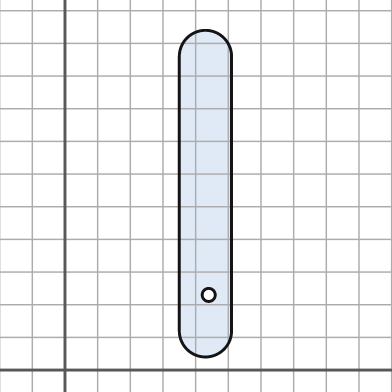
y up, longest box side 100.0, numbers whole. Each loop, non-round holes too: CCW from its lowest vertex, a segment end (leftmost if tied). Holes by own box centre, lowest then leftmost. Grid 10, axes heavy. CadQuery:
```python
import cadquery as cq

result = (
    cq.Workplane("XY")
    .moveTo(35.0, 12.0)
    .threePointArc((43.0, 4.0), (51.0, 12.0))
    .lineTo(51.0, 96.0)
    .threePointArc((43.0, 104.0), (35.0, 96.0))
    .close()
    .moveTo(44.0, 23.0)
    .circle(2.0)
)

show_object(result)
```